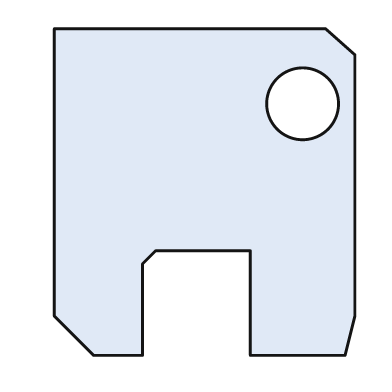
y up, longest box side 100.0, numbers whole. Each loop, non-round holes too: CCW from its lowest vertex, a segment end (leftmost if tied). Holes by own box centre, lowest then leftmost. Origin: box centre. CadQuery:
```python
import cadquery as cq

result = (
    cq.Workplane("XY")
    .moveTo(-34.0, -50.0)
    .lineTo(-19.0, -50.0)
    .lineTo(-19.0, -22.0)
    .lineTo(-15.0, -18.0)
    .lineTo(14.0, -18.0)
    .lineTo(14.0, -50.0)
    .lineTo(43.0, -50.0)
    .lineTo(46.0, -38.0)
    .lineTo(46.0, 42.0)
    .lineTo(37.0, 50.0)
    .lineTo(-46.0, 50.0)
    .lineTo(-46.0, -38.0)
    .close()
    .moveTo(30.0, 27.0)
    .circle(11.0)
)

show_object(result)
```